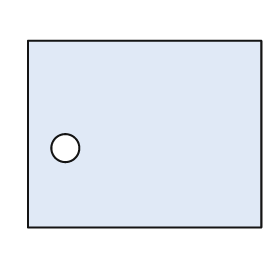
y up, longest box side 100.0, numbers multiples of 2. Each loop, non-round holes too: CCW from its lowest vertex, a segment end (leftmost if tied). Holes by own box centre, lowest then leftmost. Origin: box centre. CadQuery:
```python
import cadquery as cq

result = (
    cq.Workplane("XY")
    .moveTo(-50.0, -40.0)
    .lineTo(50.0, -40.0)
    .lineTo(50.0, 40.0)
    .lineTo(-50.0, 40.0)
    .close()
    .moveTo(-34.0, -6.0)
    .circle(6.0)
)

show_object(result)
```